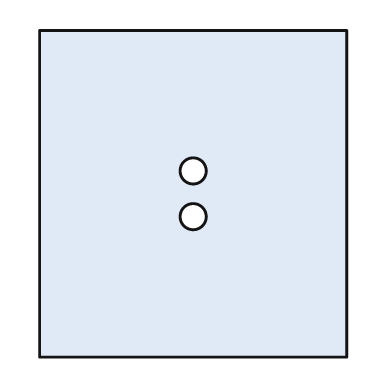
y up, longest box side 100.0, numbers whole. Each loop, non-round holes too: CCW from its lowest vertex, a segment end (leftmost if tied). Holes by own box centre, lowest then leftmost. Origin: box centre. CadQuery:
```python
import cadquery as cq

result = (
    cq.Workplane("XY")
    .moveTo(-47.0, -50.0)
    .lineTo(47.0, -50.0)
    .lineTo(47.0, 50.0)
    .lineTo(-47.0, 50.0)
    .close()
    .moveTo(0.0, -7.0)
    .circle(4.0)
    .moveTo(0.0, 7.0)
    .circle(4.0)
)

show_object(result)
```